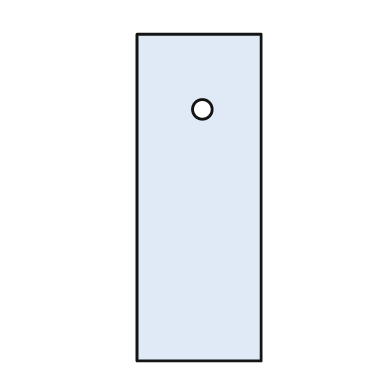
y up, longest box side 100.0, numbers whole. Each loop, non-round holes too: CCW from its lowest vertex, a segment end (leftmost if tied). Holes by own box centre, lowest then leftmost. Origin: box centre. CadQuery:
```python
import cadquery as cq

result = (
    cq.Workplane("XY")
    .moveTo(-19.0, -50.0)
    .lineTo(19.0, -50.0)
    .lineTo(19.0, 50.0)
    .lineTo(-19.0, 50.0)
    .close()
    .moveTo(1.0, 27.0)
    .circle(3.0)
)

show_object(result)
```